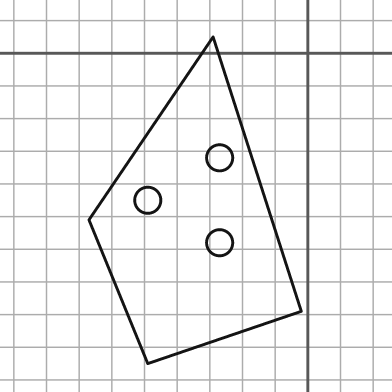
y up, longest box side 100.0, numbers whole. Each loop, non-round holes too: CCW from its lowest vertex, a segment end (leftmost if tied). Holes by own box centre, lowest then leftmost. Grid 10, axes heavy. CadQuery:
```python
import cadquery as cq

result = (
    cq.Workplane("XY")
    .moveTo(-49.0, -95.0)
    .lineTo(-2.0, -79.0)
    .lineTo(-29.0, 5.0)
    .lineTo(-67.0, -51.0)
    .close()
    .moveTo(-27.0, -58.0)
    .circle(4.0)
    .moveTo(-49.0, -45.0)
    .circle(4.0)
    .moveTo(-27.0, -32.0)
    .circle(4.0)
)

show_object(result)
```